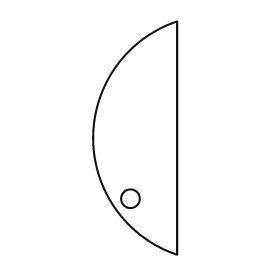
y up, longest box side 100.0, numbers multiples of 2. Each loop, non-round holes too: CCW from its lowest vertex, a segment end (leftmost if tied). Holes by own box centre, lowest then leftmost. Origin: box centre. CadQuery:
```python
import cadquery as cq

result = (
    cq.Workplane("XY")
    .moveTo(18.0, -50.0)
    .lineTo(18.0, 50.0)
    .threePointArc((-18.0, 0.0), (18.0, -50.0))
    .close()
    .moveTo(-2.0, -26.0)
    .circle(4.0)
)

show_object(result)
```